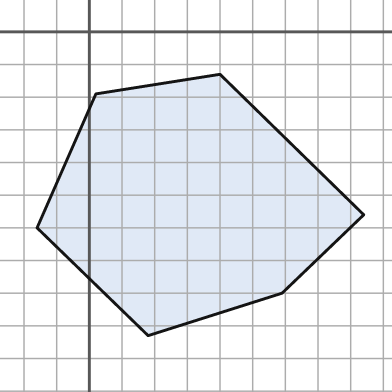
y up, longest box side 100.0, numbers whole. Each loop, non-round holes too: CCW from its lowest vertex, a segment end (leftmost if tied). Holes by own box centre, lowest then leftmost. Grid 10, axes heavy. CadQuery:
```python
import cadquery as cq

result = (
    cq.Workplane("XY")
    .moveTo(18.0, -93.0)
    .lineTo(59.0, -80.0)
    .lineTo(84.0, -56.0)
    .lineTo(40.0, -13.0)
    .lineTo(2.0, -19.0)
    .lineTo(-16.0, -60.0)
    .close()
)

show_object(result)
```